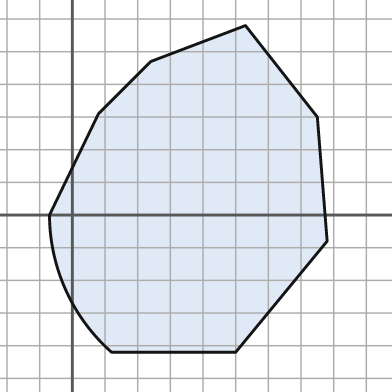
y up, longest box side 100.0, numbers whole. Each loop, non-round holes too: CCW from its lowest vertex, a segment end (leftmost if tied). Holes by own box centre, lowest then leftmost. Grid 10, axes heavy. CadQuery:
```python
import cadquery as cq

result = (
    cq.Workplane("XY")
    .moveTo(12.0, -42.0)
    .lineTo(50.0, -42.0)
    .lineTo(78.0, -8.0)
    .lineTo(75.0, 30.0)
    .lineTo(53.0, 58.0)
    .lineTo(24.0, 47.0)
    .lineTo(8.0, 31.0)
    .lineTo(-7.0, 0.0)
    .threePointArc((-2.0, -23.0), (12.0, -42.0))
    .close()
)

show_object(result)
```